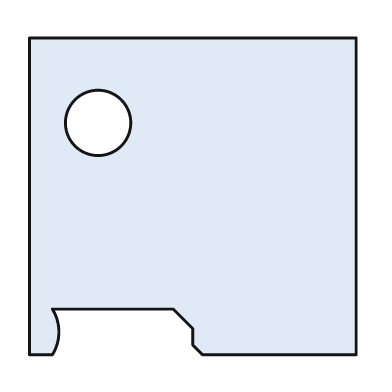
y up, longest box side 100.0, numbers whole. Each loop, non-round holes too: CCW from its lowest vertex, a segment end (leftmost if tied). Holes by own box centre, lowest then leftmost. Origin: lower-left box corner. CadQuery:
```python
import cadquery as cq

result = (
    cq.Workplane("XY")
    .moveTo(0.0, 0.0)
    .lineTo(7.0, 0.0)
    .threePointArc((9.0, 7.0), (7.0, 14.0))
    .lineTo(44.0, 14.0)
    .lineTo(50.0, 8.0)
    .lineTo(50.0, 3.0)
    .lineTo(53.0, 0.0)
    .lineTo(100.0, 0.0)
    .lineTo(100.0, 97.0)
    .lineTo(0.0, 97.0)
    .close()
    .moveTo(21.0, 71.0)
    .circle(10.0)
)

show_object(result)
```